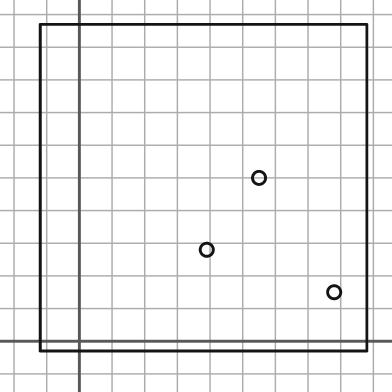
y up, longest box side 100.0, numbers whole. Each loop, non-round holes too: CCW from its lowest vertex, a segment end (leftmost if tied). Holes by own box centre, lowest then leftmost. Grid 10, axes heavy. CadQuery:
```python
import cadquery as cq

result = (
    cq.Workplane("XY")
    .moveTo(-12.0, -3.0)
    .lineTo(88.0, -3.0)
    .lineTo(88.0, 97.0)
    .lineTo(-12.0, 97.0)
    .close()
    .moveTo(78.0, 15.0)
    .circle(2.0)
    .moveTo(39.0, 28.0)
    .circle(2.0)
    .moveTo(55.0, 50.0)
    .circle(2.0)
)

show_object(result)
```